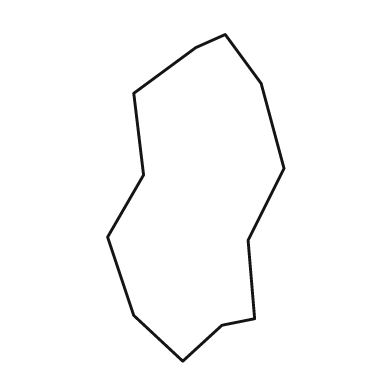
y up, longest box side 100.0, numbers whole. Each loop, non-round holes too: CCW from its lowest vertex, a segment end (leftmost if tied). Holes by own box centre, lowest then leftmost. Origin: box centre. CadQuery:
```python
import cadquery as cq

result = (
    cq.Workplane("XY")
    .moveTo(-4.0, -50.0)
    .lineTo(8.0, -39.0)
    .lineTo(18.0, -37.0)
    .lineTo(16.0, -13.0)
    .lineTo(27.0, 9.0)
    .lineTo(20.0, 35.0)
    .lineTo(9.0, 50.0)
    .lineTo(0.0, 46.0)
    .lineTo(-19.0, 32.0)
    .lineTo(-16.0, 7.0)
    .lineTo(-27.0, -12.0)
    .lineTo(-19.0, -36.0)
    .close()
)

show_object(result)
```